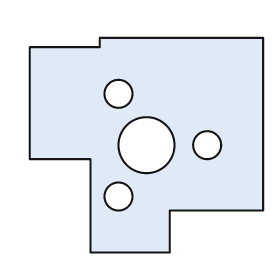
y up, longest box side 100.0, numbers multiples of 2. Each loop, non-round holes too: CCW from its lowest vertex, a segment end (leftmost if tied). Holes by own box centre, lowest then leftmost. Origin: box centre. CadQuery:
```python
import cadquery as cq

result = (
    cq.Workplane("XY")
    .moveTo(-24.0, -46.0)
    .lineTo(10.0, -46.0)
    .lineTo(10.0, -28.0)
    .lineTo(50.0, -28.0)
    .lineTo(50.0, 46.0)
    .lineTo(-20.0, 46.0)
    .lineTo(-20.0, 42.0)
    .lineTo(-50.0, 42.0)
    .lineTo(-50.0, -6.0)
    .lineTo(-24.0, -6.0)
    .close()
    .moveTo(-12.0, -22.0)
    .circle(6.0)
    .moveTo(0.0, 0.0)
    .circle(12.0)
    .moveTo(26.0, 0.0)
    .circle(6.0)
    .moveTo(-12.0, 22.0)
    .circle(6.0)
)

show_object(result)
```